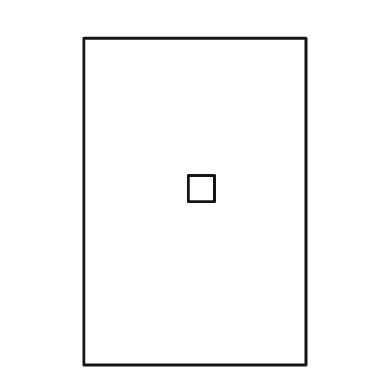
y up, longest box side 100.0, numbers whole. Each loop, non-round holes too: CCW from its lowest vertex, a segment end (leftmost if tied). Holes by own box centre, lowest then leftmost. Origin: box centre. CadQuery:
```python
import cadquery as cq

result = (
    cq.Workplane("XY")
    .moveTo(-34.0, -50.0)
    .lineTo(34.0, -50.0)
    .lineTo(34.0, 50.0)
    .lineTo(-34.0, 50.0)
    .close()
    .moveTo(-2.0, 0.0)
    .lineTo(6.0, 0.0)
    .lineTo(6.0, 8.0)
    .lineTo(-2.0, 8.0)
    .close()
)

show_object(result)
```